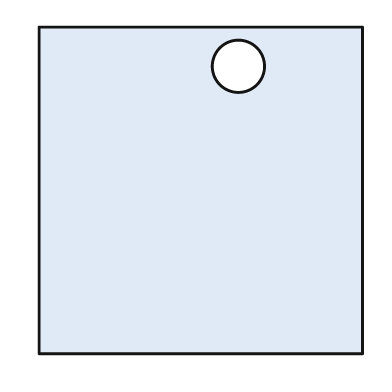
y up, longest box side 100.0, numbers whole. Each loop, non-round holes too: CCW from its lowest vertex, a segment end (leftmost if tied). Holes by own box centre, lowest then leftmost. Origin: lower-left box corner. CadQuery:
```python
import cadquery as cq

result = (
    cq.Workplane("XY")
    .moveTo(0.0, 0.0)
    .lineTo(99.0, 0.0)
    .lineTo(99.0, 100.0)
    .lineTo(0.0, 100.0)
    .close()
    .moveTo(61.0, 88.0)
    .circle(8.0)
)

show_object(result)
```